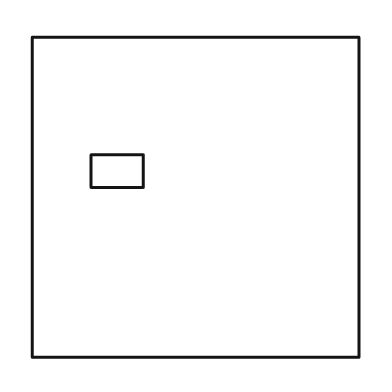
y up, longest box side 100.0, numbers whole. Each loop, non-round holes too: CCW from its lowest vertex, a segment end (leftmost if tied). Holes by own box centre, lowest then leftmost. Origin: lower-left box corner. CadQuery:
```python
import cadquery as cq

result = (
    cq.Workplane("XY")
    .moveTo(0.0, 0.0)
    .lineTo(100.0, 0.0)
    .lineTo(100.0, 98.0)
    .lineTo(0.0, 98.0)
    .close()
    .moveTo(18.0, 52.0)
    .lineTo(34.0, 52.0)
    .lineTo(34.0, 62.0)
    .lineTo(18.0, 62.0)
    .close()
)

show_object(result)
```